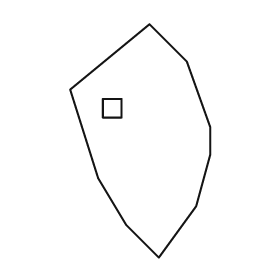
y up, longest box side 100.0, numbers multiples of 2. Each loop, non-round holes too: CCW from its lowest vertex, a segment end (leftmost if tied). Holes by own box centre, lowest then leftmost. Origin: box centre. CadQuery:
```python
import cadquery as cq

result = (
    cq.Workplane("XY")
    .moveTo(8.0, -50.0)
    .lineTo(24.0, -28.0)
    .lineTo(30.0, -6.0)
    .lineTo(30.0, 6.0)
    .lineTo(20.0, 34.0)
    .lineTo(4.0, 50.0)
    .lineTo(-30.0, 22.0)
    .lineTo(-18.0, -16.0)
    .lineTo(-6.0, -36.0)
    .close()
    .moveTo(-16.0, 10.0)
    .lineTo(-8.0, 10.0)
    .lineTo(-8.0, 18.0)
    .lineTo(-16.0, 18.0)
    .close()
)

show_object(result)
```